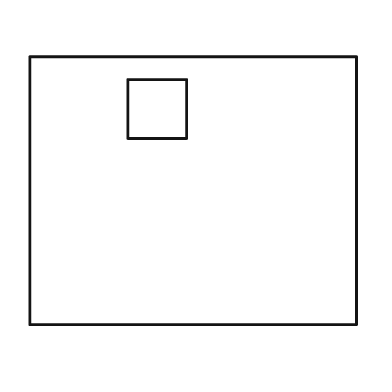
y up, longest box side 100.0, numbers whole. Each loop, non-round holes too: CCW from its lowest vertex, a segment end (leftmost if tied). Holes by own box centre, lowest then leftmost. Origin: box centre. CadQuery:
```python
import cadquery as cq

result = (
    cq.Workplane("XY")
    .moveTo(-50.0, -41.0)
    .lineTo(50.0, -41.0)
    .lineTo(50.0, 41.0)
    .lineTo(-50.0, 41.0)
    .close()
    .moveTo(-20.0, 16.0)
    .lineTo(-2.0, 16.0)
    .lineTo(-2.0, 34.0)
    .lineTo(-20.0, 34.0)
    .close()
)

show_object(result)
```